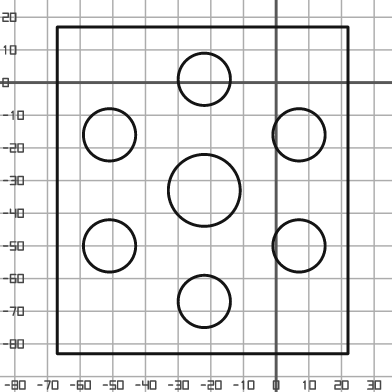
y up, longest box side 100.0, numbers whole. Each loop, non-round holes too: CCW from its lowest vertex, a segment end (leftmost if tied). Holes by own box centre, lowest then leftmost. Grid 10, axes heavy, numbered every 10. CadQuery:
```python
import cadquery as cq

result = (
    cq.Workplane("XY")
    .moveTo(-67.0, -83.0)
    .lineTo(22.0, -83.0)
    .lineTo(22.0, 17.0)
    .lineTo(-67.0, 17.0)
    .close()
    .moveTo(-22.0, -67.0)
    .circle(8.0)
    .moveTo(-51.0, -50.0)
    .circle(8.0)
    .moveTo(7.0, -50.0)
    .circle(8.0)
    .moveTo(-22.0, -33.0)
    .circle(11.0)
    .moveTo(-51.0, -16.0)
    .circle(8.0)
    .moveTo(7.0, -16.0)
    .circle(8.0)
    .moveTo(-22.0, 1.0)
    .circle(8.0)
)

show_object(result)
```